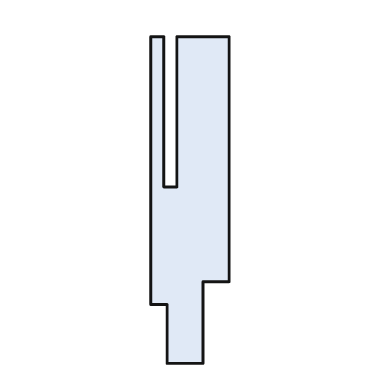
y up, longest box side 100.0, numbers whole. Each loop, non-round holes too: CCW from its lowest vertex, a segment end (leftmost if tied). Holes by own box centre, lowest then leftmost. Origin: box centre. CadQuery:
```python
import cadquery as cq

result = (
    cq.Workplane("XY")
    .moveTo(-7.0, -50.0)
    .lineTo(4.0, -50.0)
    .lineTo(4.0, -25.0)
    .lineTo(12.0, -25.0)
    .lineTo(12.0, 50.0)
    .lineTo(-4.0, 50.0)
    .lineTo(-4.0, 4.0)
    .lineTo(-8.0, 4.0)
    .lineTo(-8.0, 50.0)
    .lineTo(-12.0, 50.0)
    .lineTo(-12.0, -32.0)
    .lineTo(-7.0, -32.0)
    .close()
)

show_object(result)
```